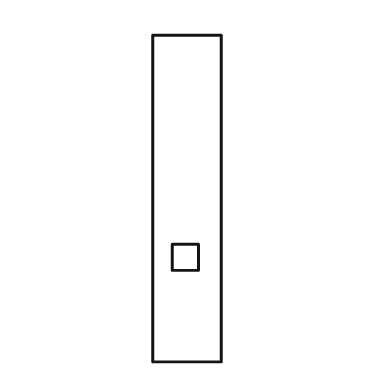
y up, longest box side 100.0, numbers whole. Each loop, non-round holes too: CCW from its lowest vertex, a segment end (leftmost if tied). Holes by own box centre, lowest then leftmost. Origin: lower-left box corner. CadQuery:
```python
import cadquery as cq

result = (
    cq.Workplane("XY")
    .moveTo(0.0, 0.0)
    .lineTo(21.0, 0.0)
    .lineTo(21.0, 100.0)
    .lineTo(0.0, 100.0)
    .close()
    .moveTo(6.0, 28.0)
    .lineTo(14.0, 28.0)
    .lineTo(14.0, 36.0)
    .lineTo(6.0, 36.0)
    .close()
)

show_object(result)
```